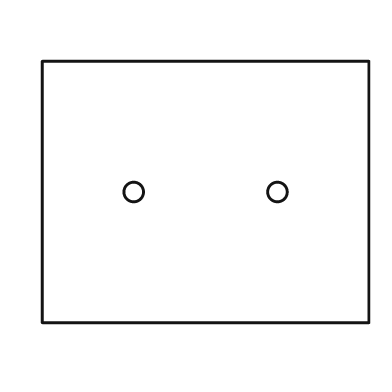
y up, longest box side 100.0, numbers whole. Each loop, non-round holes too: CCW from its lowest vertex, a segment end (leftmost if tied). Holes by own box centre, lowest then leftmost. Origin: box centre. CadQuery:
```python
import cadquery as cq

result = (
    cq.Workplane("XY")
    .moveTo(-50.0, -40.0)
    .lineTo(50.0, -40.0)
    .lineTo(50.0, 40.0)
    .lineTo(-50.0, 40.0)
    .close()
    .moveTo(-22.0, 0.0)
    .circle(3.0)
    .moveTo(22.0, 0.0)
    .circle(3.0)
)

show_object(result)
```